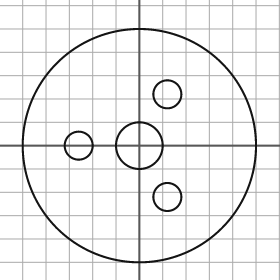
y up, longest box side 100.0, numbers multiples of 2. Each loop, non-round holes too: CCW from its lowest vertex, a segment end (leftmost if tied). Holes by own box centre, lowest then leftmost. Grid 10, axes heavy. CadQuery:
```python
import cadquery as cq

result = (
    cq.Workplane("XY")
    .moveTo(0.0, 0.0)
    .circle(50.0)
    .moveTo(12.0, -22.0)
    .circle(6.0)
    .moveTo(-26.0, 0.0)
    .circle(6.0)
    .moveTo(0.0, 0.0)
    .circle(10.0)
    .moveTo(12.0, 22.0)
    .circle(6.0)
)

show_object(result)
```